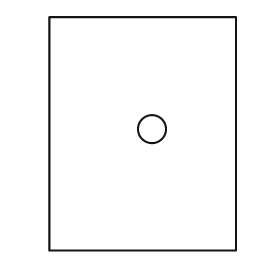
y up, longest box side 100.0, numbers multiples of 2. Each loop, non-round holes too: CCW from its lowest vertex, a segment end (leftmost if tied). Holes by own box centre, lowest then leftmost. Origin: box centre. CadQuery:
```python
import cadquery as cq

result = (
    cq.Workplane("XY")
    .moveTo(-40.0, -50.0)
    .lineTo(40.0, -50.0)
    .lineTo(40.0, 50.0)
    .lineTo(-40.0, 50.0)
    .close()
    .moveTo(4.0, 2.0)
    .circle(6.0)
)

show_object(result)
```